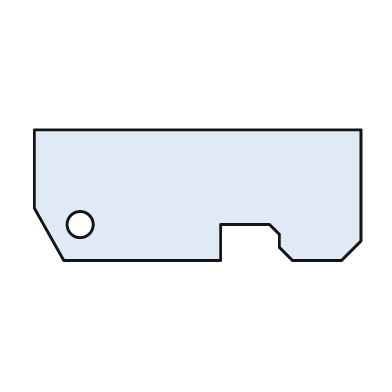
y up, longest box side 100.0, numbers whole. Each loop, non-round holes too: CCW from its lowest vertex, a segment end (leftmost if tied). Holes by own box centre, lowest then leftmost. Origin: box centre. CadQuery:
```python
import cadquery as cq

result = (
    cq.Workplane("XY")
    .moveTo(-41.0, -20.0)
    .lineTo(7.0, -20.0)
    .lineTo(7.0, -9.0)
    .lineTo(22.0, -9.0)
    .lineTo(25.0, -12.0)
    .lineTo(25.0, -16.0)
    .lineTo(29.0, -20.0)
    .lineTo(44.0, -20.0)
    .lineTo(50.0, -14.0)
    .lineTo(50.0, 20.0)
    .lineTo(-50.0, 20.0)
    .lineTo(-50.0, -4.0)
    .close()
    .moveTo(-36.0, -9.0)
    .circle(4.0)
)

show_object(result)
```